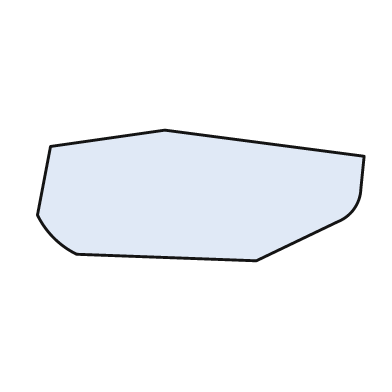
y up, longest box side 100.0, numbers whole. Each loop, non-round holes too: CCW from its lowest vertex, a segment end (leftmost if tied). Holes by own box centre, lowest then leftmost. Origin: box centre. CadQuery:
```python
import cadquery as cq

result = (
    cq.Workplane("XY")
    .moveTo(17.0, -20.0)
    .lineTo(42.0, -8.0)
    .threePointArc((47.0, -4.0), (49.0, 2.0))
    .lineTo(50.0, 12.0)
    .lineTo(-11.0, 20.0)
    .lineTo(-46.0, 15.0)
    .lineTo(-50.0, -6.0)
    .threePointArc((-45.0, -13.0), (-38.0, -18.0))
    .close()
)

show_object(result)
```